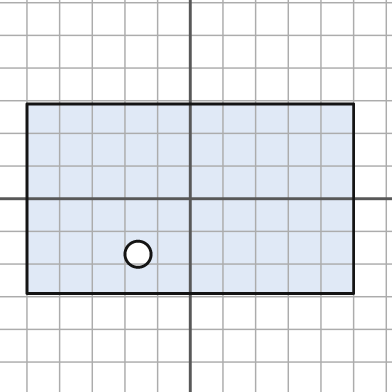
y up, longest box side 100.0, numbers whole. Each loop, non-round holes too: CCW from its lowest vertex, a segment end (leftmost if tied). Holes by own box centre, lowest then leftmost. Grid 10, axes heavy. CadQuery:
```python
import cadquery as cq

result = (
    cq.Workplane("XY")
    .moveTo(-50.0, -29.0)
    .lineTo(50.0, -29.0)
    .lineTo(50.0, 29.0)
    .lineTo(-50.0, 29.0)
    .close()
    .moveTo(-16.0, -17.0)
    .circle(4.0)
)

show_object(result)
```